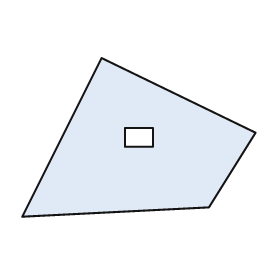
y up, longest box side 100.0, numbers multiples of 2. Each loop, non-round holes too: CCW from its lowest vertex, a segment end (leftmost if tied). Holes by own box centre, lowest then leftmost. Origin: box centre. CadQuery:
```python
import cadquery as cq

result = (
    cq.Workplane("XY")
    .moveTo(-50.0, -34.0)
    .lineTo(30.0, -30.0)
    .lineTo(50.0, 2.0)
    .lineTo(-16.0, 34.0)
    .close()
    .moveTo(-6.0, -4.0)
    .lineTo(6.0, -4.0)
    .lineTo(6.0, 4.0)
    .lineTo(-6.0, 4.0)
    .close()
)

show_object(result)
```